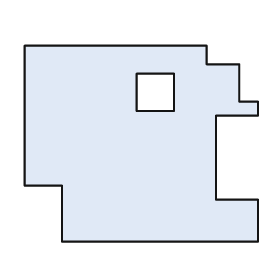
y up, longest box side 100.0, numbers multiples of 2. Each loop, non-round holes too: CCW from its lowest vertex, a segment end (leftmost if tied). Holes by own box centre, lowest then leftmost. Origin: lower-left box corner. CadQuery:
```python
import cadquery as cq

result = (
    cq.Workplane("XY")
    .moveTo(16.0, 0.0)
    .lineTo(100.0, 0.0)
    .lineTo(100.0, 18.0)
    .lineTo(82.0, 18.0)
    .lineTo(82.0, 54.0)
    .lineTo(100.0, 54.0)
    .lineTo(100.0, 60.0)
    .lineTo(92.0, 60.0)
    .lineTo(92.0, 76.0)
    .lineTo(78.0, 76.0)
    .lineTo(78.0, 84.0)
    .lineTo(0.0, 84.0)
    .lineTo(0.0, 24.0)
    .lineTo(16.0, 24.0)
    .close()
    .moveTo(48.0, 56.0)
    .lineTo(64.0, 56.0)
    .lineTo(64.0, 72.0)
    .lineTo(48.0, 72.0)
    .close()
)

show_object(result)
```